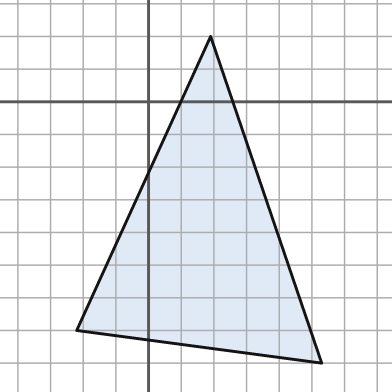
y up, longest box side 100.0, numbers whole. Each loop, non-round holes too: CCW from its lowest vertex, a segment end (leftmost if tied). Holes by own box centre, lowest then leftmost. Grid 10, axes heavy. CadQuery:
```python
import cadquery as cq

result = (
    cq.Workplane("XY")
    .moveTo(53.0, -80.0)
    .lineTo(19.0, 20.0)
    .lineTo(-22.0, -70.0)
    .close()
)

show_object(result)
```